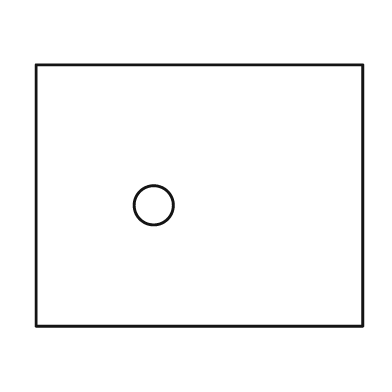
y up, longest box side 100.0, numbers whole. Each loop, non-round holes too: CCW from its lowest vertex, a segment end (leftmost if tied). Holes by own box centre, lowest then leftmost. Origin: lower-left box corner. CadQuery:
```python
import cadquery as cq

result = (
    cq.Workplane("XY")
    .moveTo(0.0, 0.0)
    .lineTo(100.0, 0.0)
    .lineTo(100.0, 80.0)
    .lineTo(0.0, 80.0)
    .close()
    .moveTo(36.0, 37.0)
    .circle(6.0)
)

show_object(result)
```